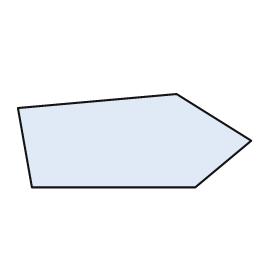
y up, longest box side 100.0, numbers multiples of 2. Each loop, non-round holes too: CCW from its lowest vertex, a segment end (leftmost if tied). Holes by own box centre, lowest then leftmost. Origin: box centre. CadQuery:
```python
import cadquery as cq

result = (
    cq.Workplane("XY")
    .moveTo(-44.0, -20.0)
    .lineTo(26.0, -20.0)
    .lineTo(50.0, 0.0)
    .lineTo(18.0, 20.0)
    .lineTo(-50.0, 14.0)
    .close()
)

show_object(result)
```